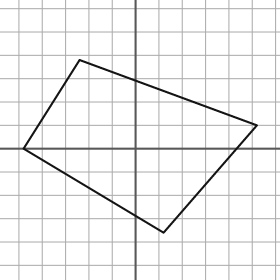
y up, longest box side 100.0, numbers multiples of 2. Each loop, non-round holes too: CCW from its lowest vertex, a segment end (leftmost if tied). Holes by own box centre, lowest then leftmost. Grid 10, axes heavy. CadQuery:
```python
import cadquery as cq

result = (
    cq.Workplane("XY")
    .moveTo(12.0, -36.0)
    .lineTo(52.0, 10.0)
    .lineTo(-24.0, 38.0)
    .lineTo(-48.0, 0.0)
    .close()
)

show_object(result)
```